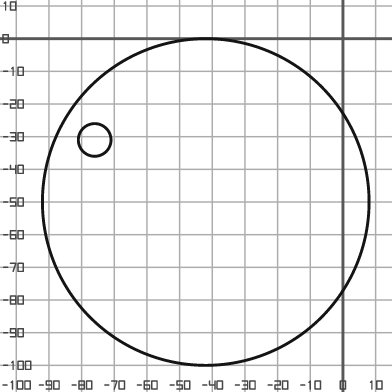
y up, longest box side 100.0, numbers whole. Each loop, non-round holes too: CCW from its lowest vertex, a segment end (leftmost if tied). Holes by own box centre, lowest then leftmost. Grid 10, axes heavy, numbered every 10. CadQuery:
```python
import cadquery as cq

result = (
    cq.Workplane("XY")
    .moveTo(-42.0, -50.0)
    .circle(50.0)
    .moveTo(-76.0, -31.0)
    .circle(5.0)
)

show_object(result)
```